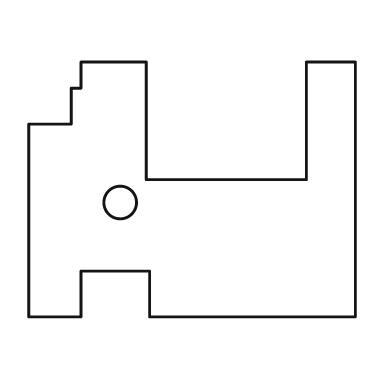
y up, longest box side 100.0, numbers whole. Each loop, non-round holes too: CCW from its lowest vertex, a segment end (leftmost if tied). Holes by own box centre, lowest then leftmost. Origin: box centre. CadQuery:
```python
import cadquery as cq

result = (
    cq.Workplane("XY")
    .moveTo(-50.0, -39.0)
    .lineTo(-34.0, -39.0)
    .lineTo(-34.0, -25.0)
    .lineTo(-13.0, -25.0)
    .lineTo(-13.0, -39.0)
    .lineTo(50.0, -39.0)
    .lineTo(50.0, 39.0)
    .lineTo(35.0, 39.0)
    .lineTo(35.0, 3.0)
    .lineTo(-14.0, 3.0)
    .lineTo(-14.0, 39.0)
    .lineTo(-34.0, 39.0)
    .lineTo(-34.0, 31.0)
    .lineTo(-37.0, 31.0)
    .lineTo(-37.0, 20.0)
    .lineTo(-50.0, 20.0)
    .close()
    .moveTo(-22.0, -4.0)
    .circle(5.0)
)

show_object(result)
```